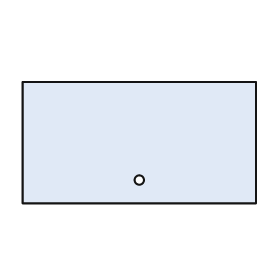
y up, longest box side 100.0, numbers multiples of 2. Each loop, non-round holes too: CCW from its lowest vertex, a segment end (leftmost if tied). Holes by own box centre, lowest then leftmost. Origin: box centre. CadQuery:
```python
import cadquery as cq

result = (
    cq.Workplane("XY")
    .moveTo(-50.0, -26.0)
    .lineTo(50.0, -26.0)
    .lineTo(50.0, 26.0)
    .lineTo(-50.0, 26.0)
    .close()
    .moveTo(0.0, -16.0)
    .circle(2.0)
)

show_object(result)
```